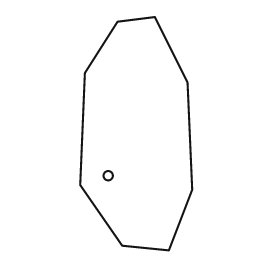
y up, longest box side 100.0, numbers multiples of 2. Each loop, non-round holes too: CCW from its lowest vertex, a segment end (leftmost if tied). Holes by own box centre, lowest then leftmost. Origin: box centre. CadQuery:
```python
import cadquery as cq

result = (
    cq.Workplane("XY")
    .moveTo(14.0, -50.0)
    .lineTo(24.0, -24.0)
    .lineTo(22.0, 22.0)
    .lineTo(8.0, 50.0)
    .lineTo(-8.0, 48.0)
    .lineTo(-22.0, 26.0)
    .lineTo(-24.0, -22.0)
    .lineTo(-6.0, -48.0)
    .close()
    .moveTo(-12.0, -18.0)
    .circle(2.0)
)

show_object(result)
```